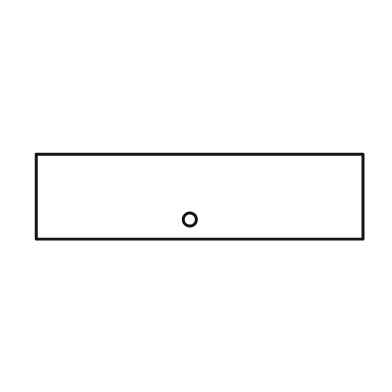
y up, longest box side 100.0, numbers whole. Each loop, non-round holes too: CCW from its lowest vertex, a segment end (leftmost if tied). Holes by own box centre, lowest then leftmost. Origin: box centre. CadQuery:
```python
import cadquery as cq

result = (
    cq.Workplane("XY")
    .moveTo(-50.0, -13.0)
    .lineTo(50.0, -13.0)
    .lineTo(50.0, 13.0)
    .lineTo(-50.0, 13.0)
    .close()
    .moveTo(-3.0, -7.0)
    .circle(2.0)
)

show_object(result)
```